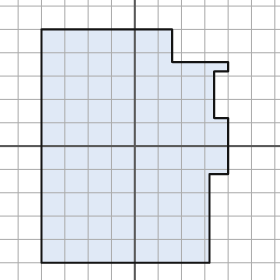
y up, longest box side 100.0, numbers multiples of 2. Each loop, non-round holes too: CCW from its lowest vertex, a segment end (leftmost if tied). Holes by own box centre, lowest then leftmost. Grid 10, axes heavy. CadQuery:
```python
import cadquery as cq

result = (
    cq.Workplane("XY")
    .moveTo(-40.0, -50.0)
    .lineTo(32.0, -50.0)
    .lineTo(32.0, -12.0)
    .lineTo(40.0, -12.0)
    .lineTo(40.0, 12.0)
    .lineTo(34.0, 12.0)
    .lineTo(34.0, 32.0)
    .lineTo(40.0, 32.0)
    .lineTo(40.0, 36.0)
    .lineTo(16.0, 36.0)
    .lineTo(16.0, 50.0)
    .lineTo(-40.0, 50.0)
    .close()
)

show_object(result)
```